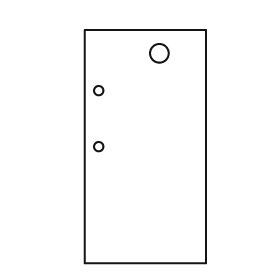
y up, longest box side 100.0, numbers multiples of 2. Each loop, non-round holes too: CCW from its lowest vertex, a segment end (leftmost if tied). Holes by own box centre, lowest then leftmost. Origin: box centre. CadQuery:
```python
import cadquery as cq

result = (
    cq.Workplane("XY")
    .moveTo(-26.0, -50.0)
    .lineTo(26.0, -50.0)
    .lineTo(26.0, 50.0)
    .lineTo(-26.0, 50.0)
    .close()
    .moveTo(-20.0, 0.0)
    .circle(2.0)
    .moveTo(-20.0, 24.0)
    .circle(2.0)
    .moveTo(6.0, 40.0)
    .circle(4.0)
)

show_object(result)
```